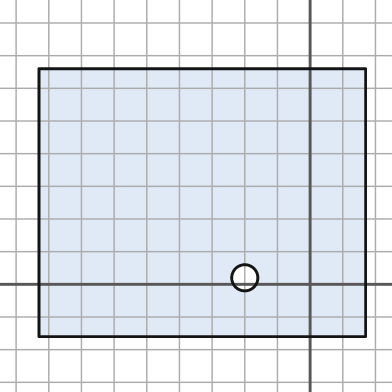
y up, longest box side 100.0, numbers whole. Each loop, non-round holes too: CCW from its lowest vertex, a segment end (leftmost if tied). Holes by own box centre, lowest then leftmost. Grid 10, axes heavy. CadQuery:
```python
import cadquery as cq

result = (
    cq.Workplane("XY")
    .moveTo(-83.0, -16.0)
    .lineTo(17.0, -16.0)
    .lineTo(17.0, 66.0)
    .lineTo(-83.0, 66.0)
    .close()
    .moveTo(-20.0, 2.0)
    .circle(4.0)
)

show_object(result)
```